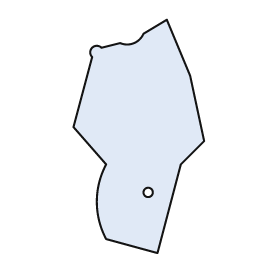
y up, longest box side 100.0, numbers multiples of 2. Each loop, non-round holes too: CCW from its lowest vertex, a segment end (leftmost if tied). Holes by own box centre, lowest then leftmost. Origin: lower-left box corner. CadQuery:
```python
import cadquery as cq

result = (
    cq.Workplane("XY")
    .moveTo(36.0, 0.0)
    .lineTo(46.0, 38.0)
    .lineTo(56.0, 48.0)
    .lineTo(50.0, 76.0)
    .lineTo(40.0, 100.0)
    .lineTo(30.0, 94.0)
    .threePointArc((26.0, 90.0), (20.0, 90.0))
    .lineTo(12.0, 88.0)
    .threePointArc((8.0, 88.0), (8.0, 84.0))
    .lineTo(0.0, 54.0)
    .lineTo(14.0, 38.0)
    .threePointArc((10.0, 22.0), (14.0, 6.0))
    .close()
    .moveTo(32.0, 26.0)
    .circle(2.0)
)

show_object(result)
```